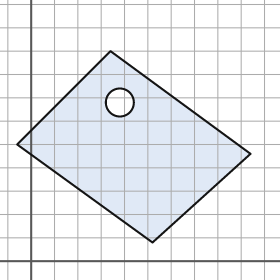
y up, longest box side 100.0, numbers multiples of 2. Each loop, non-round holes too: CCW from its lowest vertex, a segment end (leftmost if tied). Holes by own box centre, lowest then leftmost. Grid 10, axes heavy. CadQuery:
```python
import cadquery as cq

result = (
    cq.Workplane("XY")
    .moveTo(52.0, 8.0)
    .lineTo(94.0, 46.0)
    .lineTo(34.0, 90.0)
    .lineTo(-6.0, 50.0)
    .close()
    .moveTo(38.0, 68.0)
    .circle(6.0)
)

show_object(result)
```